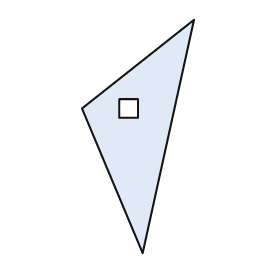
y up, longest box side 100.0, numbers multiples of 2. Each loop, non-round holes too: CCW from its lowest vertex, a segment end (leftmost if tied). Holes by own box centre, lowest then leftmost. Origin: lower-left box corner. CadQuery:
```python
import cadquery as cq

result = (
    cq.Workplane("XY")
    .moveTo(26.0, 0.0)
    .lineTo(48.0, 100.0)
    .lineTo(0.0, 62.0)
    .close()
    .moveTo(16.0, 58.0)
    .lineTo(24.0, 58.0)
    .lineTo(24.0, 66.0)
    .lineTo(16.0, 66.0)
    .close()
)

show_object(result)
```